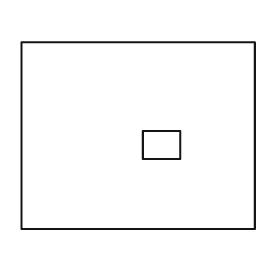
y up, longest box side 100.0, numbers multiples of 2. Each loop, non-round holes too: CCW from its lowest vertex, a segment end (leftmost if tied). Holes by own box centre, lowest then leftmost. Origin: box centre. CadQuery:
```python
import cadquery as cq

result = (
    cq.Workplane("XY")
    .moveTo(-50.0, -40.0)
    .lineTo(50.0, -40.0)
    .lineTo(50.0, 40.0)
    .lineTo(-50.0, 40.0)
    .close()
    .moveTo(2.0, -10.0)
    .lineTo(18.0, -10.0)
    .lineTo(18.0, 2.0)
    .lineTo(2.0, 2.0)
    .close()
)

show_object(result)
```